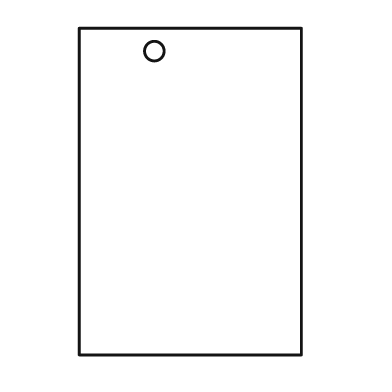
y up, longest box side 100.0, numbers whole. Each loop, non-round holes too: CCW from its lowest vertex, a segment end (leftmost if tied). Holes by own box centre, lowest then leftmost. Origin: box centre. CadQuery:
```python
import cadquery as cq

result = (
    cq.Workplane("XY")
    .moveTo(-34.0, -50.0)
    .lineTo(34.0, -50.0)
    .lineTo(34.0, 50.0)
    .lineTo(-34.0, 50.0)
    .close()
    .moveTo(-11.0, 43.0)
    .circle(3.0)
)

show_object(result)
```